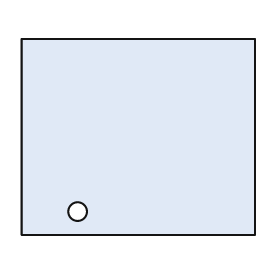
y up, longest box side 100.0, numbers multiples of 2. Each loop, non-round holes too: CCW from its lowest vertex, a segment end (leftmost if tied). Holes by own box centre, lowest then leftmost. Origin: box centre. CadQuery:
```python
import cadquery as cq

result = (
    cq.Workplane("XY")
    .moveTo(-50.0, -42.0)
    .lineTo(50.0, -42.0)
    .lineTo(50.0, 42.0)
    .lineTo(-50.0, 42.0)
    .close()
    .moveTo(-26.0, -32.0)
    .circle(4.0)
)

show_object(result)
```